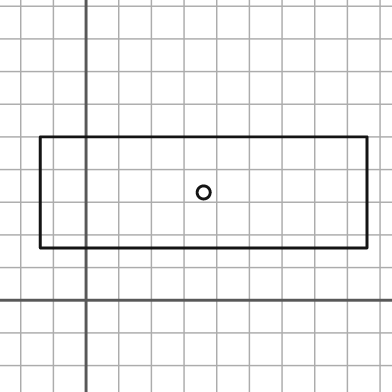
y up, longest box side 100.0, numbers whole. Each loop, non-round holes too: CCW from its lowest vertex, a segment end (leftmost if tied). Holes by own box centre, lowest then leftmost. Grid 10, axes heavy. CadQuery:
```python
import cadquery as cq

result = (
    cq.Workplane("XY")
    .moveTo(-14.0, 16.0)
    .lineTo(86.0, 16.0)
    .lineTo(86.0, 50.0)
    .lineTo(-14.0, 50.0)
    .close()
    .moveTo(36.0, 33.0)
    .circle(2.0)
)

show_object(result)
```